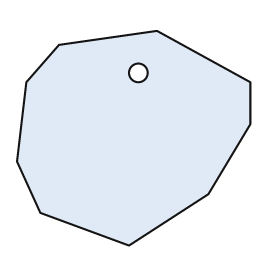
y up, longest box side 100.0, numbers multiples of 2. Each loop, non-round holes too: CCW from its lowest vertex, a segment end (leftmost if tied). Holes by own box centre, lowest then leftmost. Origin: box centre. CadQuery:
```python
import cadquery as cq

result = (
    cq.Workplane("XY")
    .moveTo(-2.0, -46.0)
    .lineTo(32.0, -24.0)
    .lineTo(50.0, 6.0)
    .lineTo(50.0, 24.0)
    .lineTo(10.0, 46.0)
    .lineTo(-32.0, 40.0)
    .lineTo(-46.0, 24.0)
    .lineTo(-50.0, -10.0)
    .lineTo(-40.0, -32.0)
    .close()
    .moveTo(2.0, 28.0)
    .circle(4.0)
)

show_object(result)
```